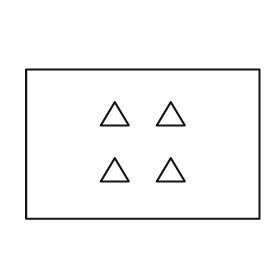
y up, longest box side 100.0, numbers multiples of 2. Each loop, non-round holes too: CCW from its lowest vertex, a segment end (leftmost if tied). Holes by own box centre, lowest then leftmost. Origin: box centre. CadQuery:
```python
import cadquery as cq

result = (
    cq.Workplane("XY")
    .moveTo(-50.0, -32.0)
    .lineTo(50.0, -32.0)
    .lineTo(50.0, 32.0)
    .lineTo(-50.0, 32.0)
    .close()
    .moveTo(-18.0, -16.0)
    .lineTo(-6.0, -16.0)
    .lineTo(-12.0, -6.0)
    .close()
    .moveTo(6.0, -16.0)
    .lineTo(18.0, -16.0)
    .lineTo(12.0, -6.0)
    .close()
    .moveTo(-18.0, 8.0)
    .lineTo(-6.0, 8.0)
    .lineTo(-12.0, 18.0)
    .close()
    .moveTo(6.0, 8.0)
    .lineTo(18.0, 8.0)
    .lineTo(12.0, 18.0)
    .close()
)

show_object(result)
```